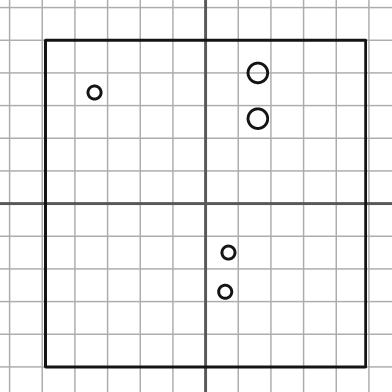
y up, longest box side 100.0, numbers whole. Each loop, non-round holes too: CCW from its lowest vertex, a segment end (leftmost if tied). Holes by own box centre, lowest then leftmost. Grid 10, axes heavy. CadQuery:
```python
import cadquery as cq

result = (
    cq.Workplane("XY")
    .moveTo(-49.0, -50.0)
    .lineTo(49.0, -50.0)
    .lineTo(49.0, 50.0)
    .lineTo(-49.0, 50.0)
    .close()
    .moveTo(6.0, -27.0)
    .circle(2.0)
    .moveTo(7.0, -15.0)
    .circle(2.0)
    .moveTo(16.0, 26.0)
    .circle(3.0)
    .moveTo(-34.0, 34.0)
    .circle(2.0)
    .moveTo(16.0, 40.0)
    .circle(3.0)
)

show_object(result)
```